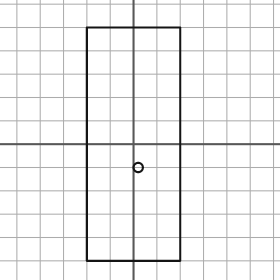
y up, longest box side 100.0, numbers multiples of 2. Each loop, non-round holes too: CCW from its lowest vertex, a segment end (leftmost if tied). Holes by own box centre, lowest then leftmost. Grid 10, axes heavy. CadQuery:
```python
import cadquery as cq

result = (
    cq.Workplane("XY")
    .moveTo(-20.0, -50.0)
    .lineTo(20.0, -50.0)
    .lineTo(20.0, 50.0)
    .lineTo(-20.0, 50.0)
    .close()
    .moveTo(2.0, -10.0)
    .circle(2.0)
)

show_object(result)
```